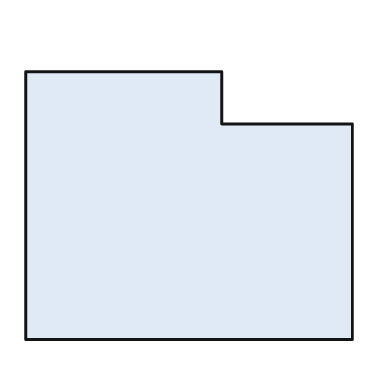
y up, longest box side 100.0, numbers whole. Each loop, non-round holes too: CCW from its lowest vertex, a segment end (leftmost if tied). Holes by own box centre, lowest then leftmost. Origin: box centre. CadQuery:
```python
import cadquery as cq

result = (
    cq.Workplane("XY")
    .moveTo(-50.0, -41.0)
    .lineTo(50.0, -41.0)
    .lineTo(50.0, 25.0)
    .lineTo(10.0, 25.0)
    .lineTo(10.0, 41.0)
    .lineTo(-50.0, 41.0)
    .close()
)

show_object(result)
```